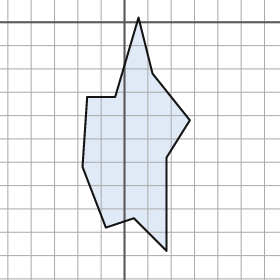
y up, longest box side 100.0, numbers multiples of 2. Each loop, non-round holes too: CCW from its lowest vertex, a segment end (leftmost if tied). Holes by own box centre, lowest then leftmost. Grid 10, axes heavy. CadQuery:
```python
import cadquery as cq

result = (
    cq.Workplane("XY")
    .moveTo(18.0, -98.0)
    .lineTo(18.0, -58.0)
    .lineTo(28.0, -42.0)
    .lineTo(12.0, -22.0)
    .lineTo(6.0, 2.0)
    .lineTo(-4.0, -32.0)
    .lineTo(-16.0, -32.0)
    .lineTo(-18.0, -62.0)
    .lineTo(-8.0, -88.0)
    .lineTo(4.0, -84.0)
    .close()
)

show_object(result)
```